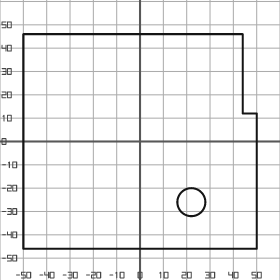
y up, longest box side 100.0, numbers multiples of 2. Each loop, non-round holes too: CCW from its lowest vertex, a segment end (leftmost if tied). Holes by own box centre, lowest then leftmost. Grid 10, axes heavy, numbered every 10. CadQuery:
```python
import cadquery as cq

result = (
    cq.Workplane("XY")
    .moveTo(-50.0, -46.0)
    .lineTo(50.0, -46.0)
    .lineTo(50.0, 12.0)
    .lineTo(44.0, 12.0)
    .lineTo(44.0, 46.0)
    .lineTo(-50.0, 46.0)
    .close()
    .moveTo(22.0, -26.0)
    .circle(6.0)
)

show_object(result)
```